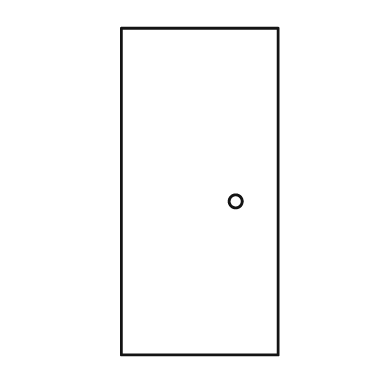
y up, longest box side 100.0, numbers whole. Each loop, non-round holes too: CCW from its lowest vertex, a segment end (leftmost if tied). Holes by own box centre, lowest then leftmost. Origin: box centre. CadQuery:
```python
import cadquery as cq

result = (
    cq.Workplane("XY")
    .moveTo(-24.0, -50.0)
    .lineTo(24.0, -50.0)
    .lineTo(24.0, 50.0)
    .lineTo(-24.0, 50.0)
    .close()
    .moveTo(11.0, -3.0)
    .circle(2.0)
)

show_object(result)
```